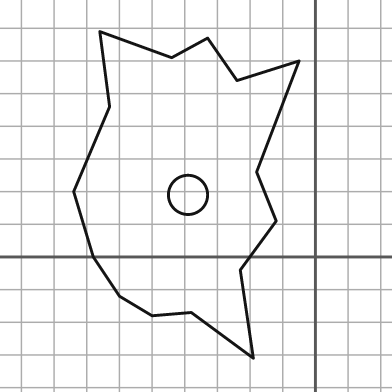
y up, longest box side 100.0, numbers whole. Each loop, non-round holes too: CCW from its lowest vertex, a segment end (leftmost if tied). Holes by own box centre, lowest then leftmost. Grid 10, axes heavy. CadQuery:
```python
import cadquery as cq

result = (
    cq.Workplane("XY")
    .moveTo(-19.0, -31.0)
    .lineTo(-23.0, -4.0)
    .lineTo(-12.0, 11.0)
    .lineTo(-18.0, 26.0)
    .lineTo(-5.0, 60.0)
    .lineTo(-24.0, 54.0)
    .lineTo(-33.0, 67.0)
    .lineTo(-44.0, 61.0)
    .lineTo(-66.0, 69.0)
    .lineTo(-63.0, 46.0)
    .lineTo(-74.0, 20.0)
    .lineTo(-68.0, 0.0)
    .lineTo(-60.0, -12.0)
    .lineTo(-50.0, -18.0)
    .lineTo(-38.0, -17.0)
    .close()
    .moveTo(-39.0, 19.0)
    .circle(6.0)
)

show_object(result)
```